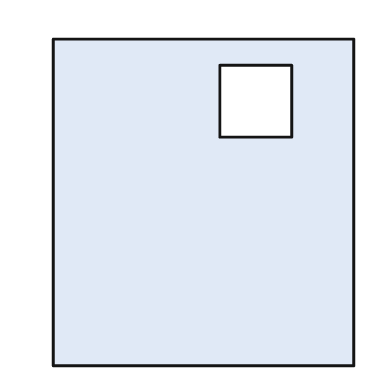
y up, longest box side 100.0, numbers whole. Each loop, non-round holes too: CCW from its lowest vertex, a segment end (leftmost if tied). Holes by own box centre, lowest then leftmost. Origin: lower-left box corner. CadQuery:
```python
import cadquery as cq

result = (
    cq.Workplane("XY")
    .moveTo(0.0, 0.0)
    .lineTo(92.0, 0.0)
    .lineTo(92.0, 100.0)
    .lineTo(0.0, 100.0)
    .close()
    .moveTo(51.0, 70.0)
    .lineTo(73.0, 70.0)
    .lineTo(73.0, 92.0)
    .lineTo(51.0, 92.0)
    .close()
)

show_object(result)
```